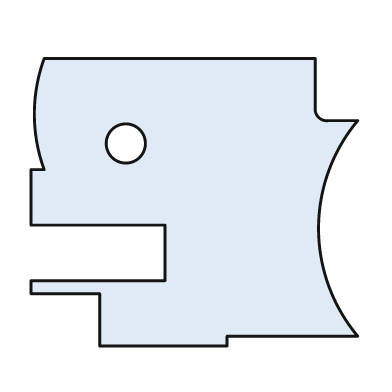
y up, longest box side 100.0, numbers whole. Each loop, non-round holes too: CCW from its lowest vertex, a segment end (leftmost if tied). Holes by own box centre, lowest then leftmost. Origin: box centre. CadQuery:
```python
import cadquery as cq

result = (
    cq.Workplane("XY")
    .moveTo(-29.0, -44.0)
    .lineTo(10.0, -44.0)
    .lineTo(10.0, -41.0)
    .lineTo(50.0, -41.0)
    .threePointArc((38.0, -8.0), (50.0, 25.0))
    .lineTo(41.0, 25.0)
    .threePointArc((38.0, 26.0), (37.0, 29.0))
    .lineTo(37.0, 44.0)
    .lineTo(-46.0, 44.0)
    .threePointArc((-49.0, 27.0), (-46.0, 10.0))
    .lineTo(-50.0, 10.0)
    .lineTo(-50.0, -7.0)
    .lineTo(-9.0, -7.0)
    .lineTo(-9.0, -24.0)
    .lineTo(-50.0, -24.0)
    .lineTo(-50.0, -28.0)
    .lineTo(-29.0, -28.0)
    .close()
    .moveTo(-21.0, 18.0)
    .circle(6.0)
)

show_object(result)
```